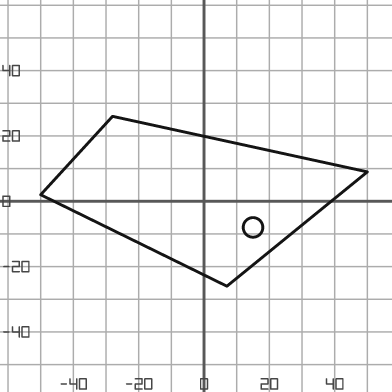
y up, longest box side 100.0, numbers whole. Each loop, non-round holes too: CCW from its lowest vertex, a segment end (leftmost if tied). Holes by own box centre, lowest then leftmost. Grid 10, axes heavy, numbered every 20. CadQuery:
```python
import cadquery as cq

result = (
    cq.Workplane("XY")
    .moveTo(7.0, -26.0)
    .lineTo(50.0, 9.0)
    .lineTo(-28.0, 26.0)
    .lineTo(-50.0, 2.0)
    .close()
    .moveTo(15.0, -8.0)
    .circle(3.0)
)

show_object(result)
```